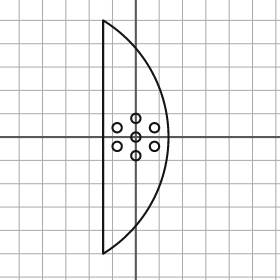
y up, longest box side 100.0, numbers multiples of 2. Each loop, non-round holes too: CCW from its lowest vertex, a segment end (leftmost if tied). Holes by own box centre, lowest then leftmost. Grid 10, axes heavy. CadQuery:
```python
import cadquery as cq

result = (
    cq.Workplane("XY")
    .moveTo(-14.0, -50.0)
    .threePointArc((14.0, 0.0), (-14.0, 50.0))
    .close()
    .moveTo(0.0, -8.0)
    .circle(2.0)
    .moveTo(-8.0, -4.0)
    .circle(2.0)
    .moveTo(8.0, -4.0)
    .circle(2.0)
    .moveTo(0.0, 0.0)
    .circle(2.0)
    .moveTo(-8.0, 4.0)
    .circle(2.0)
    .moveTo(8.0, 4.0)
    .circle(2.0)
    .moveTo(0.0, 8.0)
    .circle(2.0)
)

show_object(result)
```